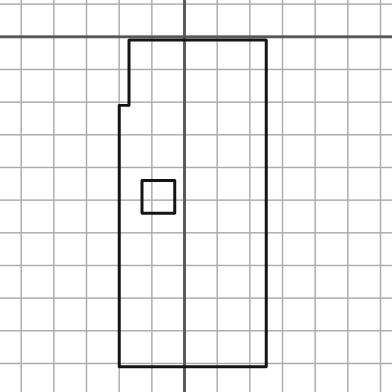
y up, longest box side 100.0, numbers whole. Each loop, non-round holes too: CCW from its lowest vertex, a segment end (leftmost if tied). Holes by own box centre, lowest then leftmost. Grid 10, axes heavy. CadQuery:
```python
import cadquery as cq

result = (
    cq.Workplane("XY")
    .moveTo(-20.0, -101.0)
    .lineTo(25.0, -101.0)
    .lineTo(25.0, -1.0)
    .lineTo(-17.0, -1.0)
    .lineTo(-17.0, -21.0)
    .lineTo(-20.0, -21.0)
    .close()
    .moveTo(-13.0, -54.0)
    .lineTo(-3.0, -54.0)
    .lineTo(-3.0, -44.0)
    .lineTo(-13.0, -44.0)
    .close()
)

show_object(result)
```